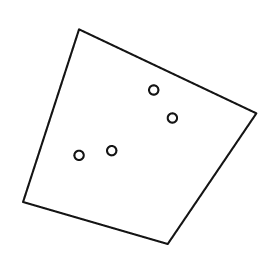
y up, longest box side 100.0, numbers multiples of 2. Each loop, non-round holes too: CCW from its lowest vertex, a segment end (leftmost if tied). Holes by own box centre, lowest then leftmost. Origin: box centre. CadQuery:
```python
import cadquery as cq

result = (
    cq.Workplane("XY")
    .moveTo(12.0, -46.0)
    .lineTo(50.0, 10.0)
    .lineTo(-26.0, 46.0)
    .lineTo(-50.0, -28.0)
    .close()
    .moveTo(-26.0, -8.0)
    .circle(2.0)
    .moveTo(-12.0, -6.0)
    .circle(2.0)
    .moveTo(14.0, 8.0)
    .circle(2.0)
    .moveTo(6.0, 20.0)
    .circle(2.0)
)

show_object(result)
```